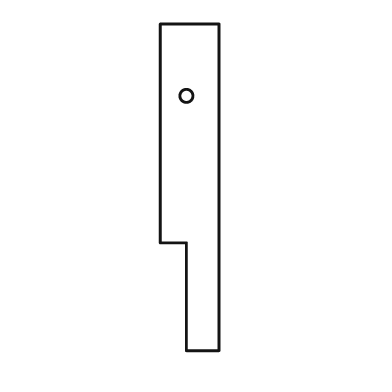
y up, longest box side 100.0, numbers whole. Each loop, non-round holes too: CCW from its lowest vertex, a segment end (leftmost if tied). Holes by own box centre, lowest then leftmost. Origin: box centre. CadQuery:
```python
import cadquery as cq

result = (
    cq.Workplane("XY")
    .moveTo(-1.0, -50.0)
    .lineTo(9.0, -50.0)
    .lineTo(9.0, 50.0)
    .lineTo(-9.0, 50.0)
    .lineTo(-9.0, -17.0)
    .lineTo(-1.0, -17.0)
    .close()
    .moveTo(-1.0, 28.0)
    .circle(2.0)
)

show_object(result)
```